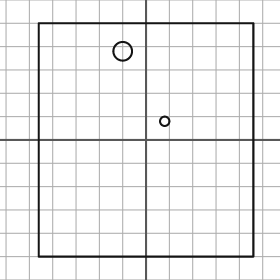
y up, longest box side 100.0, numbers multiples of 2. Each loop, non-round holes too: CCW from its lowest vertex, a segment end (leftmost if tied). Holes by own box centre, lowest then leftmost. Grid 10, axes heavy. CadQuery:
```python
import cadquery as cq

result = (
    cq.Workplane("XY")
    .moveTo(-46.0, -50.0)
    .lineTo(46.0, -50.0)
    .lineTo(46.0, 50.0)
    .lineTo(-46.0, 50.0)
    .close()
    .moveTo(8.0, 8.0)
    .circle(2.0)
    .moveTo(-10.0, 38.0)
    .circle(4.0)
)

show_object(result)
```